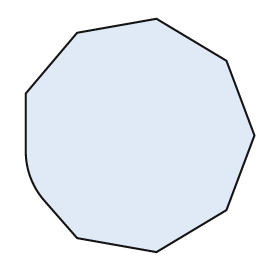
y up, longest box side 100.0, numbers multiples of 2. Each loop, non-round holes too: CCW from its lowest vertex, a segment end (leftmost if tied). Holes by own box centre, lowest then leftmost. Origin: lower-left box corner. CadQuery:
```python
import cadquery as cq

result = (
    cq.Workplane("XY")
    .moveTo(56.0, 0.0)
    .lineTo(86.0, 18.0)
    .lineTo(98.0, 50.0)
    .lineTo(86.0, 82.0)
    .lineTo(56.0, 100.0)
    .lineTo(22.0, 94.0)
    .lineTo(0.0, 68.0)
    .lineTo(0.0, 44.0)
    .threePointArc((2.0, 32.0), (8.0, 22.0))
    .lineTo(22.0, 6.0)
    .close()
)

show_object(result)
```